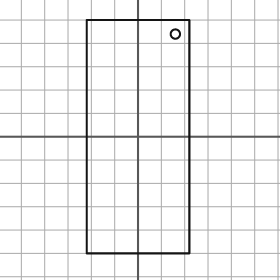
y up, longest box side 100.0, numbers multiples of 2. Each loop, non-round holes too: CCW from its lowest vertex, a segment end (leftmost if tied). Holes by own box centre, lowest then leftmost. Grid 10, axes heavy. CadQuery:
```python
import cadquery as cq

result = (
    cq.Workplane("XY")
    .moveTo(-22.0, -50.0)
    .lineTo(22.0, -50.0)
    .lineTo(22.0, 50.0)
    .lineTo(-22.0, 50.0)
    .close()
    .moveTo(16.0, 44.0)
    .circle(2.0)
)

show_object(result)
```